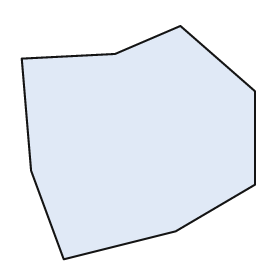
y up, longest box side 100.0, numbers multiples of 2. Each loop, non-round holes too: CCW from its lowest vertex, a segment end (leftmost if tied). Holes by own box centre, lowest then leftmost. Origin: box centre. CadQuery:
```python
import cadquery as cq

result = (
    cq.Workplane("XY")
    .moveTo(-32.0, -50.0)
    .lineTo(16.0, -38.0)
    .lineTo(50.0, -18.0)
    .lineTo(50.0, 22.0)
    .lineTo(18.0, 50.0)
    .lineTo(-10.0, 38.0)
    .lineTo(-50.0, 36.0)
    .lineTo(-46.0, -12.0)
    .close()
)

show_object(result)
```